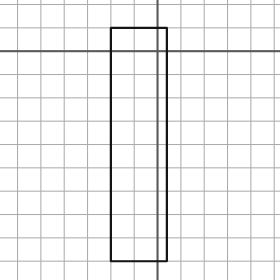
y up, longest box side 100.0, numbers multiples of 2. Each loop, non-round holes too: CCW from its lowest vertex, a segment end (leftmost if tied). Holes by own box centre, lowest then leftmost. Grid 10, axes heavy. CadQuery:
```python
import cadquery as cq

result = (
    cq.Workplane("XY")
    .moveTo(-20.0, -90.0)
    .lineTo(4.0, -90.0)
    .lineTo(4.0, 10.0)
    .lineTo(-20.0, 10.0)
    .close()
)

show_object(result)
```